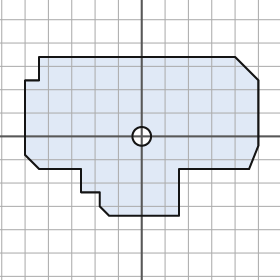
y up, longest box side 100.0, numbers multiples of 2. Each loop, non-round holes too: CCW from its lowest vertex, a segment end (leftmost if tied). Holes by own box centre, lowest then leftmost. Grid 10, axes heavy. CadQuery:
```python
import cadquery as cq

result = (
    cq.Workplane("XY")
    .moveTo(-14.0, -34.0)
    .lineTo(16.0, -34.0)
    .lineTo(16.0, -14.0)
    .lineTo(46.0, -14.0)
    .lineTo(50.0, -4.0)
    .lineTo(50.0, 24.0)
    .lineTo(40.0, 34.0)
    .lineTo(-44.0, 34.0)
    .lineTo(-44.0, 24.0)
    .lineTo(-50.0, 24.0)
    .lineTo(-50.0, -8.0)
    .lineTo(-44.0, -14.0)
    .lineTo(-26.0, -14.0)
    .lineTo(-26.0, -24.0)
    .lineTo(-18.0, -24.0)
    .lineTo(-18.0, -30.0)
    .close()
    .moveTo(0.0, 0.0)
    .circle(4.0)
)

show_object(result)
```